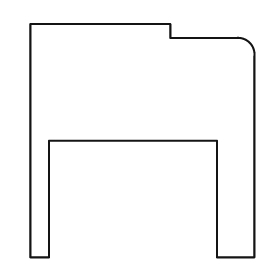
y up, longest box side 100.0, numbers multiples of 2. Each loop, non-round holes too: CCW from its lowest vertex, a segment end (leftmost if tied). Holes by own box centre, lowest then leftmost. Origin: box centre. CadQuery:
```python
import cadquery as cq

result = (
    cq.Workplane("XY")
    .moveTo(-48.0, -50.0)
    .lineTo(-40.0, -50.0)
    .lineTo(-40.0, 0.0)
    .lineTo(32.0, 0.0)
    .lineTo(32.0, -50.0)
    .lineTo(48.0, -50.0)
    .lineTo(48.0, 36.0)
    .threePointArc((46.0, 42.0), (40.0, 44.0))
    .lineTo(12.0, 44.0)
    .lineTo(12.0, 50.0)
    .lineTo(-48.0, 50.0)
    .close()
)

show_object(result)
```